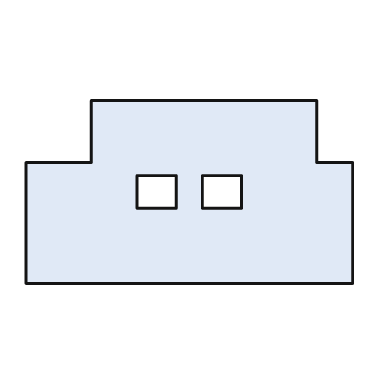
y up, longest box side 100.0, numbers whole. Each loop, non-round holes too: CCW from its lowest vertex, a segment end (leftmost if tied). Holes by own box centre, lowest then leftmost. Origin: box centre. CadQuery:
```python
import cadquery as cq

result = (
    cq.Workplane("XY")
    .moveTo(-50.0, -28.0)
    .lineTo(50.0, -28.0)
    .lineTo(50.0, 9.0)
    .lineTo(39.0, 9.0)
    .lineTo(39.0, 28.0)
    .lineTo(-30.0, 28.0)
    .lineTo(-30.0, 9.0)
    .lineTo(-50.0, 9.0)
    .close()
    .moveTo(-16.0, -5.0)
    .lineTo(-4.0, -5.0)
    .lineTo(-4.0, 5.0)
    .lineTo(-16.0, 5.0)
    .close()
    .moveTo(4.0, -5.0)
    .lineTo(16.0, -5.0)
    .lineTo(16.0, 5.0)
    .lineTo(4.0, 5.0)
    .close()
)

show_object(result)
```